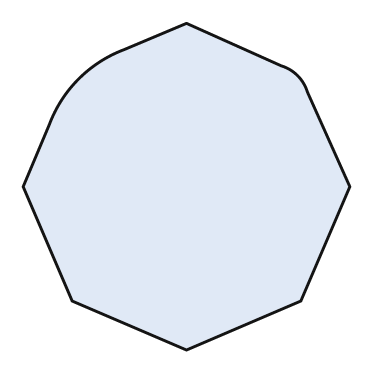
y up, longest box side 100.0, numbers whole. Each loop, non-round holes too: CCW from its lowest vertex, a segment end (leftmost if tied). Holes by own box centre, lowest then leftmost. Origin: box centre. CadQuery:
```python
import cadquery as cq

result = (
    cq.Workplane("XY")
    .moveTo(0.0, -50.0)
    .lineTo(35.0, -35.0)
    .lineTo(50.0, 0.0)
    .lineTo(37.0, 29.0)
    .threePointArc((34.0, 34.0), (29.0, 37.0))
    .lineTo(0.0, 50.0)
    .lineTo(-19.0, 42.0)
    .threePointArc((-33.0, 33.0), (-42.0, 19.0))
    .lineTo(-50.0, 0.0)
    .lineTo(-35.0, -35.0)
    .close()
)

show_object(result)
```